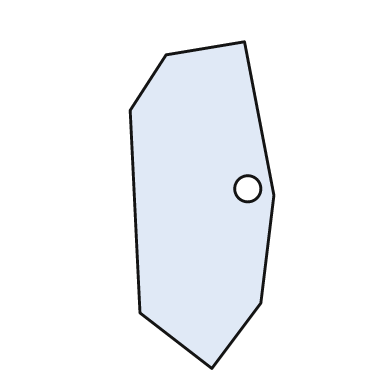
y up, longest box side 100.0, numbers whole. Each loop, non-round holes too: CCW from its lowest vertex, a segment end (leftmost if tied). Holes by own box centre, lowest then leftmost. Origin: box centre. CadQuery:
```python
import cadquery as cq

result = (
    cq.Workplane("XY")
    .moveTo(3.0, -50.0)
    .lineTo(18.0, -30.0)
    .lineTo(22.0, 3.0)
    .lineTo(13.0, 50.0)
    .lineTo(-11.0, 46.0)
    .lineTo(-22.0, 29.0)
    .lineTo(-19.0, -33.0)
    .close()
    .moveTo(14.0, 5.0)
    .circle(4.0)
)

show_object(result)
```